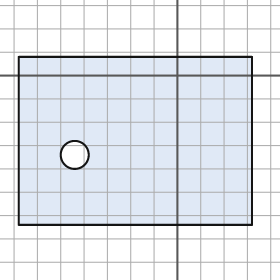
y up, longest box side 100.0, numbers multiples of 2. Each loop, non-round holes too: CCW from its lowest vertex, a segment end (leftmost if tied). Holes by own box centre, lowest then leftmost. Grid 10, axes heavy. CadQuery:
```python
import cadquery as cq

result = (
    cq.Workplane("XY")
    .moveTo(-68.0, -64.0)
    .lineTo(32.0, -64.0)
    .lineTo(32.0, 8.0)
    .lineTo(-68.0, 8.0)
    .close()
    .moveTo(-44.0, -34.0)
    .circle(6.0)
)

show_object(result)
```